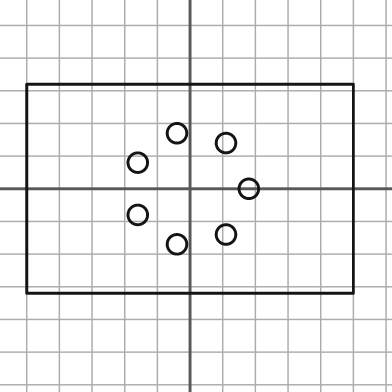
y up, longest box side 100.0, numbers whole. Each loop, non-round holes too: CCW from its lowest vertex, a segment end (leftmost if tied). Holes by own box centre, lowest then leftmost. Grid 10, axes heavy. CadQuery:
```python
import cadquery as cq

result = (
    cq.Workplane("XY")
    .moveTo(-50.0, -32.0)
    .lineTo(50.0, -32.0)
    .lineTo(50.0, 32.0)
    .lineTo(-50.0, 32.0)
    .close()
    .moveTo(-4.0, -17.0)
    .circle(3.0)
    .moveTo(11.0, -14.0)
    .circle(3.0)
    .moveTo(-16.0, -8.0)
    .circle(3.0)
    .moveTo(18.0, 0.0)
    .circle(3.0)
    .moveTo(-16.0, 8.0)
    .circle(3.0)
    .moveTo(11.0, 14.0)
    .circle(3.0)
    .moveTo(-4.0, 17.0)
    .circle(3.0)
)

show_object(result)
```